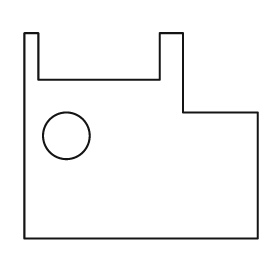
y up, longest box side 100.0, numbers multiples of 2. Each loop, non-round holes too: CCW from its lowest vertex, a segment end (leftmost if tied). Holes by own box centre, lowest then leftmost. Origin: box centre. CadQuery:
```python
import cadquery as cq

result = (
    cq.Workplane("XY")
    .moveTo(-50.0, -44.0)
    .lineTo(50.0, -44.0)
    .lineTo(50.0, 10.0)
    .lineTo(18.0, 10.0)
    .lineTo(18.0, 44.0)
    .lineTo(8.0, 44.0)
    .lineTo(8.0, 24.0)
    .lineTo(-44.0, 24.0)
    .lineTo(-44.0, 44.0)
    .lineTo(-50.0, 44.0)
    .close()
    .moveTo(-32.0, 0.0)
    .circle(10.0)
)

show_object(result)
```